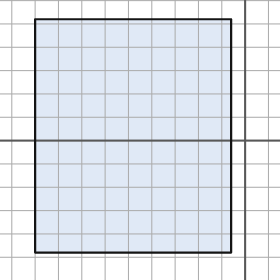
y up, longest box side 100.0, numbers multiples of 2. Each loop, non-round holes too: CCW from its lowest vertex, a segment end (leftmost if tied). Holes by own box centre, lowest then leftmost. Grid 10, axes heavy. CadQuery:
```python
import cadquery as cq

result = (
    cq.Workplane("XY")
    .moveTo(-90.0, -48.0)
    .lineTo(-6.0, -48.0)
    .lineTo(-6.0, 52.0)
    .lineTo(-90.0, 52.0)
    .close()
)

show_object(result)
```